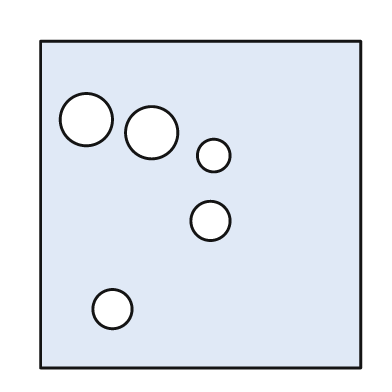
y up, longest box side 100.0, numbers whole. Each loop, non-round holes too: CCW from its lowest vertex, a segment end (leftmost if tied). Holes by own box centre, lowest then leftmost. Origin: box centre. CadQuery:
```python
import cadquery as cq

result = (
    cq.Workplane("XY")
    .moveTo(-49.0, -50.0)
    .lineTo(49.0, -50.0)
    .lineTo(49.0, 50.0)
    .lineTo(-49.0, 50.0)
    .close()
    .moveTo(-27.0, -32.0)
    .circle(6.0)
    .moveTo(3.0, -5.0)
    .circle(6.0)
    .moveTo(4.0, 15.0)
    .circle(5.0)
    .moveTo(-15.0, 22.0)
    .circle(8.0)
    .moveTo(-35.0, 26.0)
    .circle(8.0)
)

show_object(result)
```